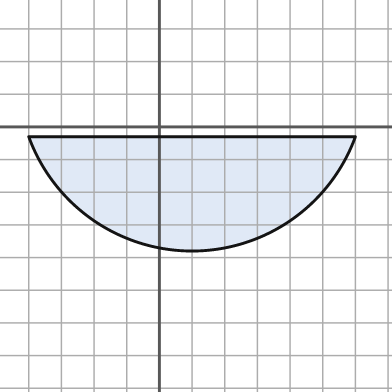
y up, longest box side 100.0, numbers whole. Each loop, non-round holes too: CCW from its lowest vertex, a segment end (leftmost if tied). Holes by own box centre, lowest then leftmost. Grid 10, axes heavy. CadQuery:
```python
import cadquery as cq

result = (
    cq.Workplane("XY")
    .moveTo(-40.0, -3.0)
    .threePointArc((10.0, -38.0), (60.0, -3.0))
    .close()
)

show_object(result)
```